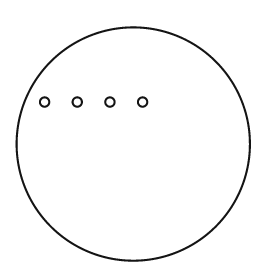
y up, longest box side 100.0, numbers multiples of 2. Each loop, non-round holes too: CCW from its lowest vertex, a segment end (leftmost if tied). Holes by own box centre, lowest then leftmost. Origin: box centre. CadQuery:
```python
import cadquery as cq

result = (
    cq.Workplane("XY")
    .moveTo(0.0, 0.0)
    .circle(50.0)
    .moveTo(-38.0, 18.0)
    .circle(2.0)
    .moveTo(-24.0, 18.0)
    .circle(2.0)
    .moveTo(-10.0, 18.0)
    .circle(2.0)
    .moveTo(4.0, 18.0)
    .circle(2.0)
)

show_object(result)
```